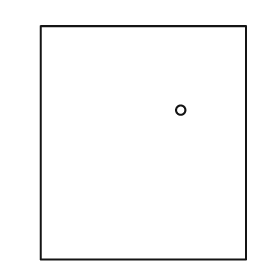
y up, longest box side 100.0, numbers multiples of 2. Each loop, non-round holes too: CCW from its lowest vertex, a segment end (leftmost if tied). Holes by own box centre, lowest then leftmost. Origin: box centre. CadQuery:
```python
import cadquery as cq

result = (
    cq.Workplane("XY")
    .moveTo(-44.0, -50.0)
    .lineTo(44.0, -50.0)
    .lineTo(44.0, 50.0)
    .lineTo(-44.0, 50.0)
    .close()
    .moveTo(16.0, 14.0)
    .circle(2.0)
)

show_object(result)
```